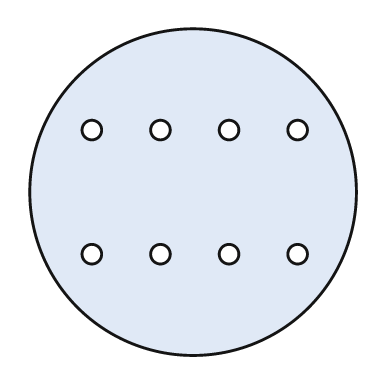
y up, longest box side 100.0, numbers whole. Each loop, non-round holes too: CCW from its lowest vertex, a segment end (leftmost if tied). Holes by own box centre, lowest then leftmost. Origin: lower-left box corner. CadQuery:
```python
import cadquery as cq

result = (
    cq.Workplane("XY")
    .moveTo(50.0, 50.0)
    .circle(50.0)
    .moveTo(19.0, 31.0)
    .circle(3.0)
    .moveTo(40.0, 31.0)
    .circle(3.0)
    .moveTo(61.0, 31.0)
    .circle(3.0)
    .moveTo(82.0, 31.0)
    .circle(3.0)
    .moveTo(19.0, 69.0)
    .circle(3.0)
    .moveTo(40.0, 69.0)
    .circle(3.0)
    .moveTo(61.0, 69.0)
    .circle(3.0)
    .moveTo(82.0, 69.0)
    .circle(3.0)
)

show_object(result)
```